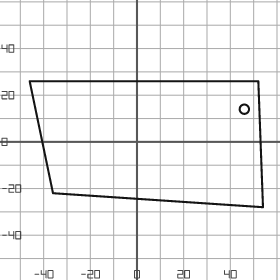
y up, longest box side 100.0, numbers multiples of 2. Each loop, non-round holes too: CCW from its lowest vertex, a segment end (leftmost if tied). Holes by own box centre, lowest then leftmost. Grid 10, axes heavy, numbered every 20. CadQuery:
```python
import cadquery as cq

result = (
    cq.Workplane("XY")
    .moveTo(54.0, -28.0)
    .lineTo(52.0, 26.0)
    .lineTo(-46.0, 26.0)
    .lineTo(-36.0, -22.0)
    .close()
    .moveTo(46.0, 14.0)
    .circle(2.0)
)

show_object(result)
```